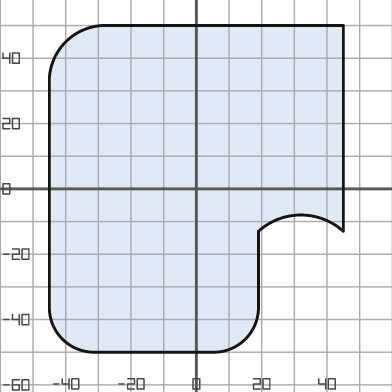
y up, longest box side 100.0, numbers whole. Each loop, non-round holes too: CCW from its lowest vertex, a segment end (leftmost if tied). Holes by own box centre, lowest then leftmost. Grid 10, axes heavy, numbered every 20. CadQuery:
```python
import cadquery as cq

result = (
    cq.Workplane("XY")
    .moveTo(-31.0, -50.0)
    .lineTo(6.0, -50.0)
    .threePointArc((15.0, -46.0), (19.0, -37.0))
    .lineTo(19.0, -13.0)
    .threePointArc((32.0, -8.0), (45.0, -13.0))
    .lineTo(45.0, 50.0)
    .lineTo(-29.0, 50.0)
    .threePointArc((-40.0, 45.0), (-45.0, 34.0))
    .lineTo(-45.0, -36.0)
    .threePointArc((-41.0, -46.0), (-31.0, -50.0))
    .close()
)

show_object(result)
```